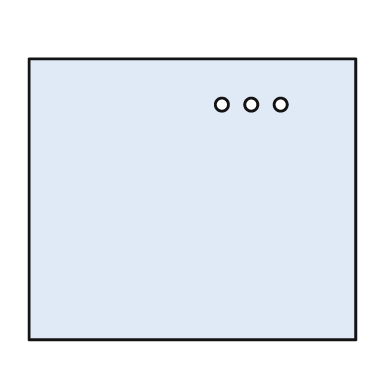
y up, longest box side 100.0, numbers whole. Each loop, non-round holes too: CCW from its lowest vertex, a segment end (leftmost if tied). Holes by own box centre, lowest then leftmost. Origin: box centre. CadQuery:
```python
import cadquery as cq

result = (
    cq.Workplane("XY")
    .moveTo(-50.0, -43.0)
    .lineTo(50.0, -43.0)
    .lineTo(50.0, 43.0)
    .lineTo(-50.0, 43.0)
    .close()
    .moveTo(9.0, 29.0)
    .circle(2.0)
    .moveTo(18.0, 29.0)
    .circle(2.0)
    .moveTo(27.0, 29.0)
    .circle(2.0)
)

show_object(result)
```